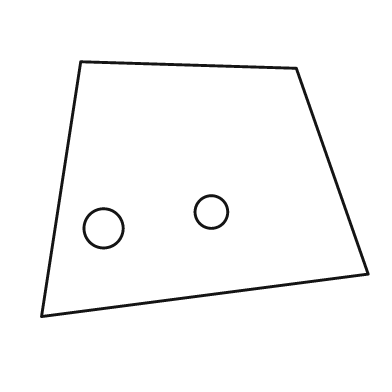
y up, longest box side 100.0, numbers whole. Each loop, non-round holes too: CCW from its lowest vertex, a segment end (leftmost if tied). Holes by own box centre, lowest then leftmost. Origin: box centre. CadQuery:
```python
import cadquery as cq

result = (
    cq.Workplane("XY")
    .moveTo(-50.0, -39.0)
    .lineTo(50.0, -26.0)
    .lineTo(28.0, 37.0)
    .lineTo(-38.0, 39.0)
    .close()
    .moveTo(-31.0, -12.0)
    .circle(6.0)
    .moveTo(2.0, -7.0)
    .circle(5.0)
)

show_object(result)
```